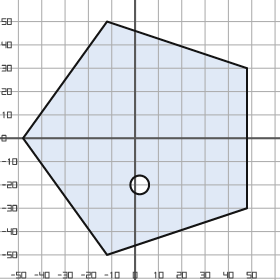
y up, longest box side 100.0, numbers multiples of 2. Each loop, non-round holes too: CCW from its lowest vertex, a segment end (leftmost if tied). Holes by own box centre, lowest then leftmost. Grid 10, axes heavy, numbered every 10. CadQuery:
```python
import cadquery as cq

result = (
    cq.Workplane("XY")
    .moveTo(-12.0, -50.0)
    .lineTo(48.0, -30.0)
    .lineTo(48.0, 30.0)
    .lineTo(-12.0, 50.0)
    .lineTo(-48.0, 0.0)
    .close()
    .moveTo(2.0, -20.0)
    .circle(4.0)
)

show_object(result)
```